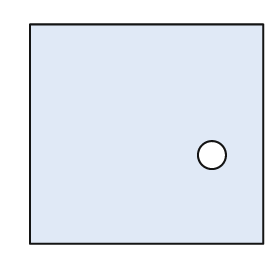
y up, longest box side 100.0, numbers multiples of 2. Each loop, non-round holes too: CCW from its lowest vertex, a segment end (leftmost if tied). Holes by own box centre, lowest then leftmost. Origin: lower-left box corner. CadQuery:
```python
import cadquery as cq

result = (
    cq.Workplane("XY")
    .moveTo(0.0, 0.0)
    .lineTo(100.0, 0.0)
    .lineTo(100.0, 94.0)
    .lineTo(0.0, 94.0)
    .close()
    .moveTo(78.0, 38.0)
    .circle(6.0)
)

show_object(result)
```